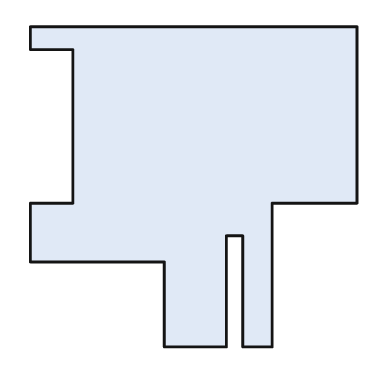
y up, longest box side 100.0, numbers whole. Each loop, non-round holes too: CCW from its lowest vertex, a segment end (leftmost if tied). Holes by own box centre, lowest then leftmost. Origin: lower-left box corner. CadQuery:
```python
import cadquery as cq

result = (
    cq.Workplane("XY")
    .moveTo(41.0, 0.0)
    .lineTo(60.0, 0.0)
    .lineTo(60.0, 34.0)
    .lineTo(65.0, 34.0)
    .lineTo(65.0, 0.0)
    .lineTo(74.0, 0.0)
    .lineTo(74.0, 44.0)
    .lineTo(100.0, 44.0)
    .lineTo(100.0, 98.0)
    .lineTo(0.0, 98.0)
    .lineTo(0.0, 91.0)
    .lineTo(13.0, 91.0)
    .lineTo(13.0, 44.0)
    .lineTo(0.0, 44.0)
    .lineTo(0.0, 26.0)
    .lineTo(41.0, 26.0)
    .close()
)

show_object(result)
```